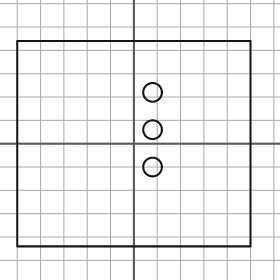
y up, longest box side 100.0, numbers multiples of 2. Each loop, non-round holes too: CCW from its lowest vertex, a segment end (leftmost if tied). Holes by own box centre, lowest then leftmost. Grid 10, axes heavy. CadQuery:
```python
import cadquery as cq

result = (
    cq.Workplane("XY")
    .moveTo(-50.0, -44.0)
    .lineTo(50.0, -44.0)
    .lineTo(50.0, 44.0)
    .lineTo(-50.0, 44.0)
    .close()
    .moveTo(8.0, -10.0)
    .circle(4.0)
    .moveTo(8.0, 6.0)
    .circle(4.0)
    .moveTo(8.0, 22.0)
    .circle(4.0)
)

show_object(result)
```